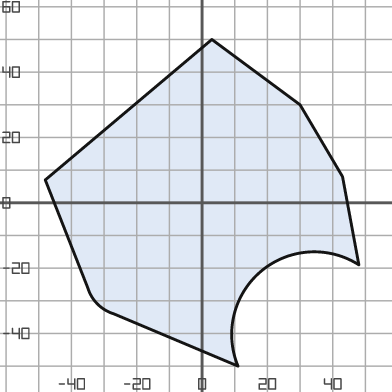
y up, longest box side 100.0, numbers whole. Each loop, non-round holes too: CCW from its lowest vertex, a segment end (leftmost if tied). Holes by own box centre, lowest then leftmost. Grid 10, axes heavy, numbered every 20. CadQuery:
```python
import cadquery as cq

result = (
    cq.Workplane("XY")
    .moveTo(11.0, -50.0)
    .threePointArc((18.0, -21.0), (48.0, -19.0))
    .lineTo(43.0, 8.0)
    .lineTo(30.0, 30.0)
    .lineTo(3.0, 50.0)
    .lineTo(-48.0, 7.0)
    .lineTo(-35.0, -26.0)
    .threePointArc((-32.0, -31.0), (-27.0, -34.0))
    .close()
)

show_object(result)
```